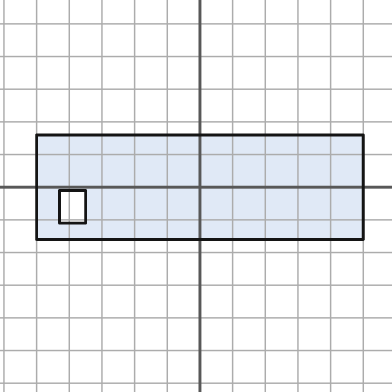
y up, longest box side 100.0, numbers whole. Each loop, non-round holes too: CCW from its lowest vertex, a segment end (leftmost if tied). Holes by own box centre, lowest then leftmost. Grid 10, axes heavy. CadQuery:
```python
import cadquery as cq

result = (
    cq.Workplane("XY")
    .moveTo(-50.0, -16.0)
    .lineTo(50.0, -16.0)
    .lineTo(50.0, 16.0)
    .lineTo(-50.0, 16.0)
    .close()
    .moveTo(-43.0, -11.0)
    .lineTo(-35.0, -11.0)
    .lineTo(-35.0, -1.0)
    .lineTo(-43.0, -1.0)
    .close()
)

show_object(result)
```